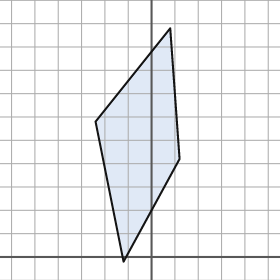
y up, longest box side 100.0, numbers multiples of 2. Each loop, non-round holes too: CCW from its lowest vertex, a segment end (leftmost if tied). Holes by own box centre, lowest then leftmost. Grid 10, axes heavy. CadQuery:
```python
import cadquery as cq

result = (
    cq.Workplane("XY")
    .moveTo(-12.0, -2.0)
    .lineTo(12.0, 42.0)
    .lineTo(8.0, 98.0)
    .lineTo(-24.0, 58.0)
    .close()
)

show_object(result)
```